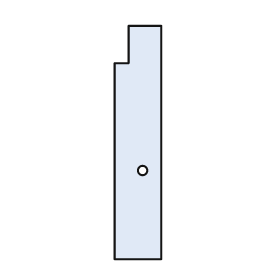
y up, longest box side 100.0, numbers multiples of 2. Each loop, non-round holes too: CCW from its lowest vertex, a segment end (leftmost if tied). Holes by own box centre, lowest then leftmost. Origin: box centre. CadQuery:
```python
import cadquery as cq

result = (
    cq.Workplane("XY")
    .moveTo(-10.0, -50.0)
    .lineTo(10.0, -50.0)
    .lineTo(10.0, 50.0)
    .lineTo(-4.0, 50.0)
    .lineTo(-4.0, 34.0)
    .lineTo(-10.0, 34.0)
    .close()
    .moveTo(2.0, -12.0)
    .circle(2.0)
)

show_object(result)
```